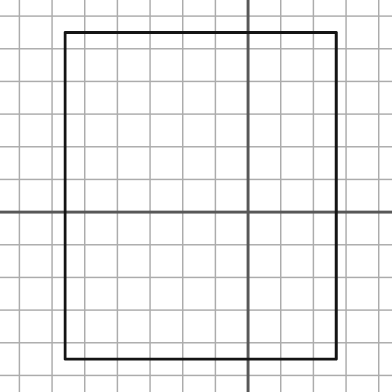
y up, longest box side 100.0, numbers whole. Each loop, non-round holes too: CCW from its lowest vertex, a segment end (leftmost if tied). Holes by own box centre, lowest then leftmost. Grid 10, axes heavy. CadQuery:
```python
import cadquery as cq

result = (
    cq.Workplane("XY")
    .moveTo(-56.0, -45.0)
    .lineTo(27.0, -45.0)
    .lineTo(27.0, 55.0)
    .lineTo(-56.0, 55.0)
    .close()
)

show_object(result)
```